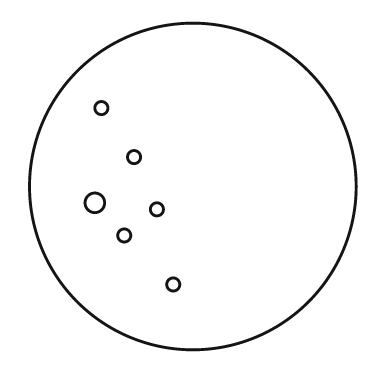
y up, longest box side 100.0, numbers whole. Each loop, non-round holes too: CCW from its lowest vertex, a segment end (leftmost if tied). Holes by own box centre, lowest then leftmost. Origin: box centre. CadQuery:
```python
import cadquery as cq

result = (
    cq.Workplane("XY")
    .moveTo(0.0, 0.0)
    .circle(50.0)
    .moveTo(-6.0, -30.0)
    .circle(2.0)
    .moveTo(-21.0, -15.0)
    .circle(2.0)
    .moveTo(-11.0, -7.0)
    .circle(2.0)
    .moveTo(-30.0, -5.0)
    .circle(3.0)
    .moveTo(-18.0, 9.0)
    .circle(2.0)
    .moveTo(-28.0, 24.0)
    .circle(2.0)
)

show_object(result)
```